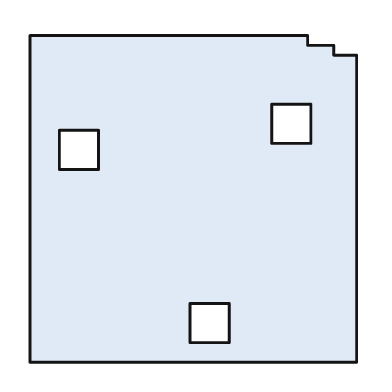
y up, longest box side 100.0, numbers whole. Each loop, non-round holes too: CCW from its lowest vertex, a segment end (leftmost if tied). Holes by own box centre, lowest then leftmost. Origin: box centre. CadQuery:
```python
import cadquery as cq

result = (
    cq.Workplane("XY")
    .moveTo(-50.0, -50.0)
    .lineTo(50.0, -50.0)
    .lineTo(50.0, 44.0)
    .lineTo(43.0, 44.0)
    .lineTo(43.0, 47.0)
    .lineTo(35.0, 47.0)
    .lineTo(35.0, 50.0)
    .lineTo(-50.0, 50.0)
    .close()
    .moveTo(-1.0, -44.0)
    .lineTo(11.0, -44.0)
    .lineTo(11.0, -32.0)
    .lineTo(-1.0, -32.0)
    .close()
    .moveTo(-41.0, 9.0)
    .lineTo(-29.0, 9.0)
    .lineTo(-29.0, 21.0)
    .lineTo(-41.0, 21.0)
    .close()
    .moveTo(24.0, 17.0)
    .lineTo(36.0, 17.0)
    .lineTo(36.0, 29.0)
    .lineTo(24.0, 29.0)
    .close()
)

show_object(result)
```